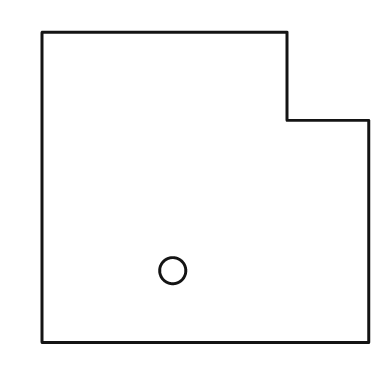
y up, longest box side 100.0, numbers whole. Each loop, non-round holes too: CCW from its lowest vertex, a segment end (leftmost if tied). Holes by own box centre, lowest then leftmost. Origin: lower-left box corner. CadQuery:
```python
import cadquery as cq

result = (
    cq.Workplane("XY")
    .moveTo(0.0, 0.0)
    .lineTo(100.0, 0.0)
    .lineTo(100.0, 68.0)
    .lineTo(75.0, 68.0)
    .lineTo(75.0, 95.0)
    .lineTo(0.0, 95.0)
    .close()
    .moveTo(40.0, 22.0)
    .circle(4.0)
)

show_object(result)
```